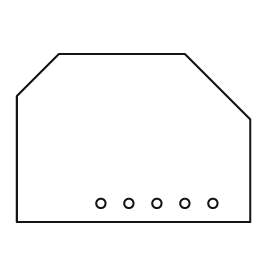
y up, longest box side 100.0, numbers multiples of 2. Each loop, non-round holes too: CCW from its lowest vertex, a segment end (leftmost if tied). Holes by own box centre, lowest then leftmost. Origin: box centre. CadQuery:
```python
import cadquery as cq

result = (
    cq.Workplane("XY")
    .moveTo(-50.0, -36.0)
    .lineTo(50.0, -36.0)
    .lineTo(50.0, 8.0)
    .lineTo(22.0, 36.0)
    .lineTo(-32.0, 36.0)
    .lineTo(-50.0, 18.0)
    .close()
    .moveTo(-14.0, -28.0)
    .circle(2.0)
    .moveTo(-2.0, -28.0)
    .circle(2.0)
    .moveTo(10.0, -28.0)
    .circle(2.0)
    .moveTo(22.0, -28.0)
    .circle(2.0)
    .moveTo(34.0, -28.0)
    .circle(2.0)
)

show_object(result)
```